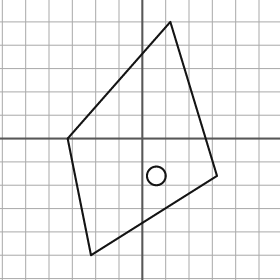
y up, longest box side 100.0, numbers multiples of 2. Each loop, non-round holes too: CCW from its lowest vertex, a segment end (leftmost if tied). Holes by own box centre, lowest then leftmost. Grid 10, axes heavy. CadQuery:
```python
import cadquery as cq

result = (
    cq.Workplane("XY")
    .moveTo(-22.0, -50.0)
    .lineTo(32.0, -16.0)
    .lineTo(12.0, 50.0)
    .lineTo(-32.0, 0.0)
    .close()
    .moveTo(6.0, -16.0)
    .circle(4.0)
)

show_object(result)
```